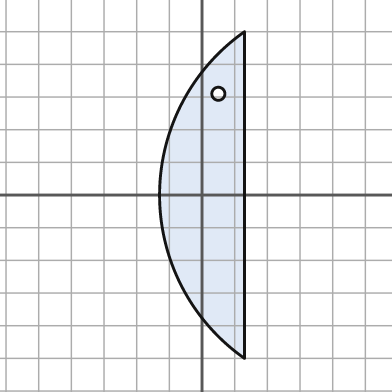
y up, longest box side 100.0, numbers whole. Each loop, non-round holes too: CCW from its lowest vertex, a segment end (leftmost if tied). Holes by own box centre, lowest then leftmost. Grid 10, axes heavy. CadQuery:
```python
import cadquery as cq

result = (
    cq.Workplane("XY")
    .moveTo(13.0, -50.0)
    .lineTo(13.0, 50.0)
    .threePointArc((-13.0, 0.0), (13.0, -50.0))
    .close()
    .moveTo(5.0, 31.0)
    .circle(2.0)
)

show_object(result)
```